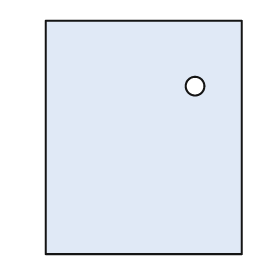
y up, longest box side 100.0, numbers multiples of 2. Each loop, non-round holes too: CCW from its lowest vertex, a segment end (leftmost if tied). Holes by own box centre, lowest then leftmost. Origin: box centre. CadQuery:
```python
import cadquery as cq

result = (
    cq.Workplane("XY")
    .moveTo(-42.0, -50.0)
    .lineTo(42.0, -50.0)
    .lineTo(42.0, 50.0)
    .lineTo(-42.0, 50.0)
    .close()
    .moveTo(22.0, 22.0)
    .circle(4.0)
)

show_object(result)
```